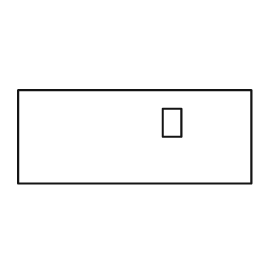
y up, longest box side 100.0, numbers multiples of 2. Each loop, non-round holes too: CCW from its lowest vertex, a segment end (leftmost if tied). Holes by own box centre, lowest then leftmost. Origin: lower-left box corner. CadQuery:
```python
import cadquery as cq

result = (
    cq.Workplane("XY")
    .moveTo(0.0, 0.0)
    .lineTo(100.0, 0.0)
    .lineTo(100.0, 40.0)
    .lineTo(0.0, 40.0)
    .close()
    .moveTo(62.0, 20.0)
    .lineTo(70.0, 20.0)
    .lineTo(70.0, 32.0)
    .lineTo(62.0, 32.0)
    .close()
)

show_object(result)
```